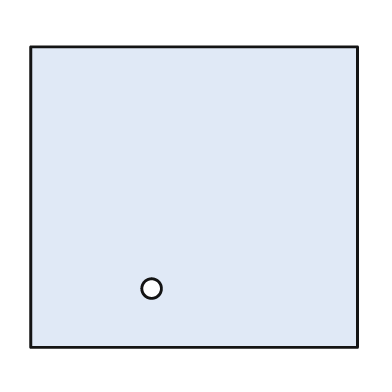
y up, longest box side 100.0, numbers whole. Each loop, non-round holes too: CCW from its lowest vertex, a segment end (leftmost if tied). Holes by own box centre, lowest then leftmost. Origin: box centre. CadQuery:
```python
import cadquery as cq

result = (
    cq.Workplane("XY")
    .moveTo(-50.0, -46.0)
    .lineTo(50.0, -46.0)
    .lineTo(50.0, 46.0)
    .lineTo(-50.0, 46.0)
    .close()
    .moveTo(-13.0, -28.0)
    .circle(3.0)
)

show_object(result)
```